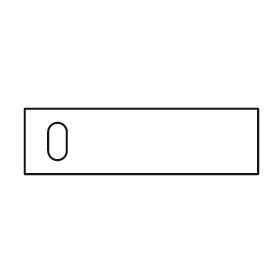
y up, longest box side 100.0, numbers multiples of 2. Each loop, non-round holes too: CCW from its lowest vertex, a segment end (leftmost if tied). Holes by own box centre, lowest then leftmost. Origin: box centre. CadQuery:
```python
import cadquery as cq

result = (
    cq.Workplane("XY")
    .moveTo(-50.0, -14.0)
    .lineTo(50.0, -14.0)
    .lineTo(50.0, 14.0)
    .lineTo(-50.0, 14.0)
    .close()
    .moveTo(-40.0, -4.0)
    .threePointArc((-36.0, -8.0), (-32.0, -4.0))
    .lineTo(-32.0, 4.0)
    .threePointArc((-36.0, 8.0), (-40.0, 4.0))
    .close()
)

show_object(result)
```